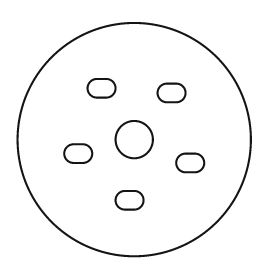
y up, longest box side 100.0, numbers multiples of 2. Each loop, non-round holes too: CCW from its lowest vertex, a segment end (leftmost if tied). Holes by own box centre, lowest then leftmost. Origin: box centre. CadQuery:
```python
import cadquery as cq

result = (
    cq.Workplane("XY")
    .moveTo(0.0, 0.0)
    .circle(50.0)
    .moveTo(-4.0, -30.0)
    .lineTo(0.0, -30.0)
    .threePointArc((4.0, -26.0), (0.0, -22.0))
    .lineTo(-4.0, -22.0)
    .threePointArc((-8.0, -26.0), (-4.0, -30.0))
    .close()
    .moveTo(22.0, -14.0)
    .lineTo(26.0, -14.0)
    .threePointArc((30.0, -10.0), (26.0, -6.0))
    .lineTo(22.0, -6.0)
    .threePointArc((18.0, -10.0), (22.0, -14.0))
    .close()
    .moveTo(-26.0, -10.0)
    .lineTo(-22.0, -10.0)
    .threePointArc((-18.0, -6.0), (-22.0, -2.0))
    .lineTo(-26.0, -2.0)
    .threePointArc((-30.0, -6.0), (-26.0, -10.0))
    .close()
    .moveTo(0.0, 0.0)
    .circle(8.0)
    .moveTo(14.0, 16.0)
    .lineTo(18.0, 16.0)
    .threePointArc((22.0, 20.0), (18.0, 24.0))
    .lineTo(14.0, 24.0)
    .threePointArc((10.0, 20.0), (14.0, 16.0))
    .close()
    .moveTo(-16.0, 18.0)
    .lineTo(-12.0, 18.0)
    .threePointArc((-8.0, 22.0), (-12.0, 26.0))
    .lineTo(-16.0, 26.0)
    .threePointArc((-20.0, 22.0), (-16.0, 18.0))
    .close()
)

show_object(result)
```